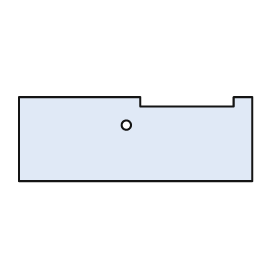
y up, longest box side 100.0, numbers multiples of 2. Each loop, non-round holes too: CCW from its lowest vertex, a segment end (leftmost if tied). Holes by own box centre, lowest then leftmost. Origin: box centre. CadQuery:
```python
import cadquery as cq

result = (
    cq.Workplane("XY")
    .moveTo(-50.0, -18.0)
    .lineTo(50.0, -18.0)
    .lineTo(50.0, 18.0)
    .lineTo(42.0, 18.0)
    .lineTo(42.0, 14.0)
    .lineTo(2.0, 14.0)
    .lineTo(2.0, 18.0)
    .lineTo(-50.0, 18.0)
    .close()
    .moveTo(-4.0, 6.0)
    .circle(2.0)
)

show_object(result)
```